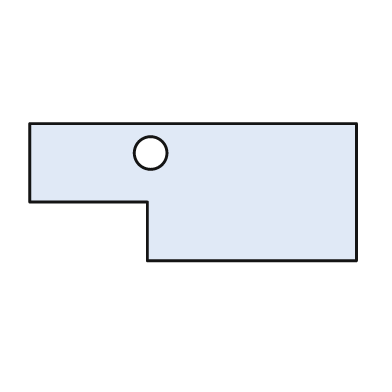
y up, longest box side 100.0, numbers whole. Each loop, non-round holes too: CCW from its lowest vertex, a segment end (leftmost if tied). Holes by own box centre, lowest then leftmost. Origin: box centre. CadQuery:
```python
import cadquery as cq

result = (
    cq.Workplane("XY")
    .moveTo(-14.0, -21.0)
    .lineTo(50.0, -21.0)
    .lineTo(50.0, 21.0)
    .lineTo(-50.0, 21.0)
    .lineTo(-50.0, -3.0)
    .lineTo(-14.0, -3.0)
    .close()
    .moveTo(-13.0, 12.0)
    .circle(5.0)
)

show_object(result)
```